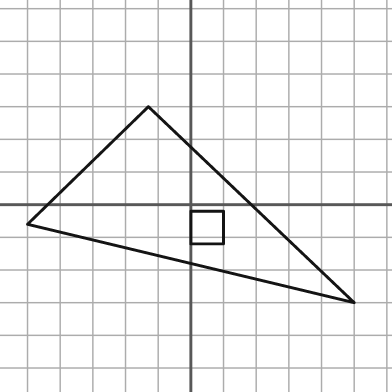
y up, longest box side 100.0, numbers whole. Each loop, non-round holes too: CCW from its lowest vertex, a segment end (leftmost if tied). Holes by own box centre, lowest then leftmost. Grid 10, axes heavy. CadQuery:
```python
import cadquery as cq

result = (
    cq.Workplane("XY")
    .moveTo(50.0, -30.0)
    .lineTo(-13.0, 30.0)
    .lineTo(-50.0, -6.0)
    .close()
    .moveTo(0.0, -12.0)
    .lineTo(10.0, -12.0)
    .lineTo(10.0, -2.0)
    .lineTo(0.0, -2.0)
    .close()
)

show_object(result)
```